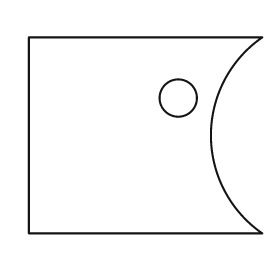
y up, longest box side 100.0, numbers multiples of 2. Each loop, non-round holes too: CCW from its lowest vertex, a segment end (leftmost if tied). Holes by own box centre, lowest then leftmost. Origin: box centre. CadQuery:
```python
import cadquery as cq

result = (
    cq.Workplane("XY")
    .moveTo(-50.0, -42.0)
    .lineTo(50.0, -42.0)
    .threePointArc((28.0, 0.0), (50.0, 42.0))
    .lineTo(-50.0, 42.0)
    .close()
    .moveTo(14.0, 16.0)
    .circle(8.0)
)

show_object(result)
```